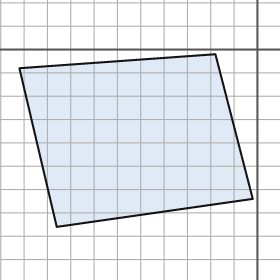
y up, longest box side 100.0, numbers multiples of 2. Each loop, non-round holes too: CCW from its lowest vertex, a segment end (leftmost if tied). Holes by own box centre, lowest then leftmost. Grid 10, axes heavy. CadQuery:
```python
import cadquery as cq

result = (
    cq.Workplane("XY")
    .moveTo(-86.0, -76.0)
    .lineTo(-2.0, -64.0)
    .lineTo(-18.0, -2.0)
    .lineTo(-102.0, -8.0)
    .close()
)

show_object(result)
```